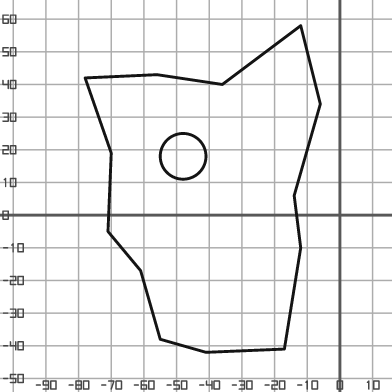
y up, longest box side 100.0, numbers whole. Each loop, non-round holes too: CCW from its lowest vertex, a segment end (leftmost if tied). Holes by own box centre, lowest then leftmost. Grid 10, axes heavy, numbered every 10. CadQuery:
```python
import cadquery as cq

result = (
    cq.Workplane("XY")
    .moveTo(-41.0, -42.0)
    .lineTo(-17.0, -41.0)
    .lineTo(-12.0, -10.0)
    .lineTo(-14.0, 6.0)
    .lineTo(-6.0, 34.0)
    .lineTo(-12.0, 58.0)
    .lineTo(-36.0, 40.0)
    .lineTo(-56.0, 43.0)
    .lineTo(-78.0, 42.0)
    .lineTo(-70.0, 19.0)
    .lineTo(-71.0, -5.0)
    .lineTo(-61.0, -17.0)
    .lineTo(-55.0, -38.0)
    .close()
    .moveTo(-48.0, 18.0)
    .circle(7.0)
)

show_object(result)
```